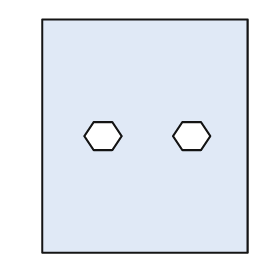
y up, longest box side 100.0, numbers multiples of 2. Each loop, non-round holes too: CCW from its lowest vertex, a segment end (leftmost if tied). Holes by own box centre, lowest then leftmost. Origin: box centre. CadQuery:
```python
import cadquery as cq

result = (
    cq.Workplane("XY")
    .moveTo(-44.0, -50.0)
    .lineTo(44.0, -50.0)
    .lineTo(44.0, 50.0)
    .lineTo(-44.0, 50.0)
    .close()
    .moveTo(-22.0, -6.0)
    .lineTo(-14.0, -6.0)
    .lineTo(-10.0, 0.0)
    .lineTo(-14.0, 6.0)
    .lineTo(-22.0, 6.0)
    .lineTo(-26.0, 0.0)
    .close()
    .moveTo(16.0, -6.0)
    .lineTo(24.0, -6.0)
    .lineTo(28.0, 0.0)
    .lineTo(24.0, 6.0)
    .lineTo(16.0, 6.0)
    .lineTo(12.0, 0.0)
    .close()
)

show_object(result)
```